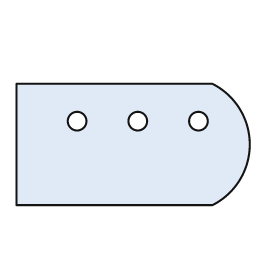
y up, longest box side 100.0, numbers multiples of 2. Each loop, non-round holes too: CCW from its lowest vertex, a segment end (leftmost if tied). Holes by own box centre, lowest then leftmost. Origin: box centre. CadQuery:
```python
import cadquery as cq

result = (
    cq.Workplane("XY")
    .moveTo(-50.0, -26.0)
    .lineTo(34.0, -26.0)
    .threePointArc((50.0, 0.0), (34.0, 26.0))
    .lineTo(-50.0, 26.0)
    .close()
    .moveTo(-24.0, 10.0)
    .circle(4.0)
    .moveTo(2.0, 10.0)
    .circle(4.0)
    .moveTo(28.0, 10.0)
    .circle(4.0)
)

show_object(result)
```